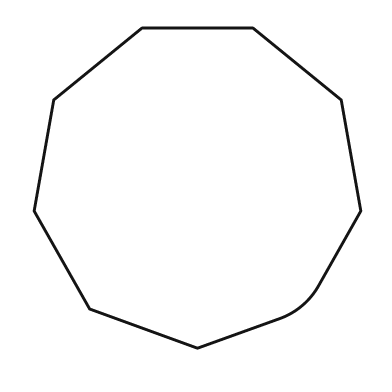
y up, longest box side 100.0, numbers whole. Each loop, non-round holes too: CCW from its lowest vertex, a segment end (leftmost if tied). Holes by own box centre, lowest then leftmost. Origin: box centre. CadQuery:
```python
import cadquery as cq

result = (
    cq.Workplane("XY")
    .moveTo(0.0, -49.0)
    .lineTo(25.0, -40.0)
    .threePointArc((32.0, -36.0), (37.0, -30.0))
    .lineTo(50.0, -7.0)
    .lineTo(44.0, 27.0)
    .lineTo(17.0, 49.0)
    .lineTo(-17.0, 49.0)
    .lineTo(-44.0, 27.0)
    .lineTo(-50.0, -7.0)
    .lineTo(-33.0, -37.0)
    .close()
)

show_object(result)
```